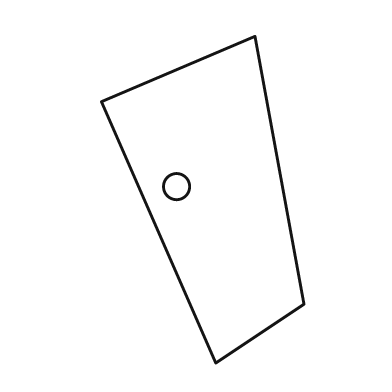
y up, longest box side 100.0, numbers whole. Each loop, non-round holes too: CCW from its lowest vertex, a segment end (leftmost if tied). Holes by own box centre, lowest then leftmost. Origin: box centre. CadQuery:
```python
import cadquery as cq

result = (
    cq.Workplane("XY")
    .moveTo(4.0, -50.0)
    .lineTo(31.0, -32.0)
    .lineTo(16.0, 50.0)
    .lineTo(-31.0, 30.0)
    .close()
    .moveTo(-8.0, 4.0)
    .circle(4.0)
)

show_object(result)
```